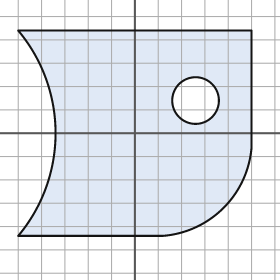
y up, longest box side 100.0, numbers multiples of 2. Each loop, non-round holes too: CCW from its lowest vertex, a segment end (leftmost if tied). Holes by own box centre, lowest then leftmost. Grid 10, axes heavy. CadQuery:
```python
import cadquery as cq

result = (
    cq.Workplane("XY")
    .moveTo(-50.0, -44.0)
    .lineTo(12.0, -44.0)
    .threePointArc((38.0, -32.0), (50.0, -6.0))
    .lineTo(50.0, 44.0)
    .lineTo(-50.0, 44.0)
    .threePointArc((-34.0, 0.0), (-50.0, -44.0))
    .close()
    .moveTo(26.0, 14.0)
    .circle(10.0)
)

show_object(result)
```